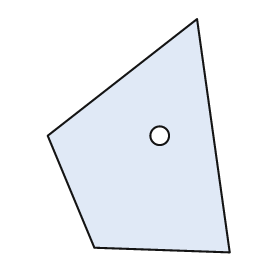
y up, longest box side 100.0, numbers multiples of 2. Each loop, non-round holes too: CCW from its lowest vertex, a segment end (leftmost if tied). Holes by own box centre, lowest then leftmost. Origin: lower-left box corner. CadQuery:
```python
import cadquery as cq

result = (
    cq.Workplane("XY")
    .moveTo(78.0, 0.0)
    .lineTo(64.0, 100.0)
    .lineTo(0.0, 50.0)
    .lineTo(20.0, 2.0)
    .close()
    .moveTo(48.0, 50.0)
    .circle(4.0)
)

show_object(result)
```